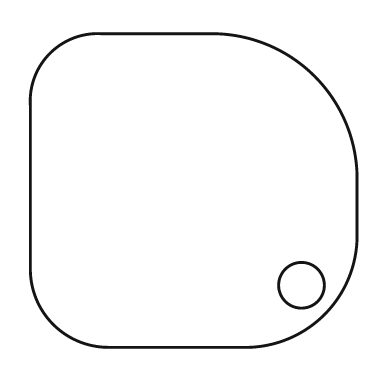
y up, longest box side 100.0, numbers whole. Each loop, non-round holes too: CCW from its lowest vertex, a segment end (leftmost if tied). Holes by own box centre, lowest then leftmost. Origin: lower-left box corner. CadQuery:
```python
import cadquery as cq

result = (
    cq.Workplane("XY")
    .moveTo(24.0, 0.0)
    .lineTo(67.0, 0.0)
    .threePointArc((90.0, 10.0), (100.0, 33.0))
    .lineTo(100.0, 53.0)
    .threePointArc((87.0, 83.0), (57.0, 96.0))
    .lineTo(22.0, 96.0)
    .threePointArc((6.0, 90.0), (0.0, 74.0))
    .lineTo(0.0, 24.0)
    .threePointArc((7.0, 7.0), (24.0, 0.0))
    .close()
    .moveTo(83.0, 19.0)
    .circle(7.0)
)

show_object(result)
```